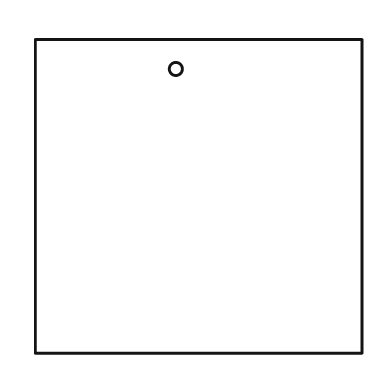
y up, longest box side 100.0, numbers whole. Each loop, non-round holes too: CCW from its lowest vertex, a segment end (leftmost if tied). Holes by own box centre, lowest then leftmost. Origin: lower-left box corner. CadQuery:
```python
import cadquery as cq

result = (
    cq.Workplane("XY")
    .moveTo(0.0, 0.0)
    .lineTo(100.0, 0.0)
    .lineTo(100.0, 96.0)
    .lineTo(0.0, 96.0)
    .close()
    .moveTo(43.0, 87.0)
    .circle(2.0)
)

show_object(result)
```